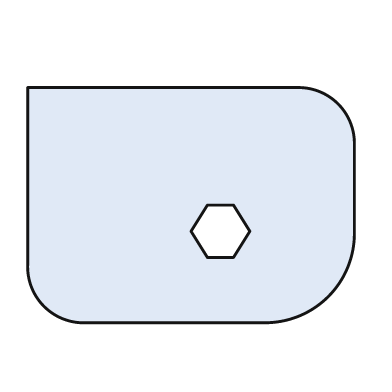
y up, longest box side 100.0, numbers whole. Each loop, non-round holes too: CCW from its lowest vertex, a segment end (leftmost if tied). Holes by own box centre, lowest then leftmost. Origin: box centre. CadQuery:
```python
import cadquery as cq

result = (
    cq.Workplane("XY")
    .moveTo(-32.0, -36.0)
    .lineTo(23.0, -36.0)
    .threePointArc((42.0, -28.0), (50.0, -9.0))
    .lineTo(50.0, 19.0)
    .threePointArc((45.0, 31.0), (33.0, 36.0))
    .lineTo(-50.0, 36.0)
    .lineTo(-50.0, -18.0)
    .threePointArc((-45.0, -31.0), (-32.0, -36.0))
    .close()
    .moveTo(5.0, -16.0)
    .lineTo(13.0, -16.0)
    .lineTo(18.0, -8.0)
    .lineTo(13.0, 0.0)
    .lineTo(5.0, 0.0)
    .lineTo(0.0, -8.0)
    .close()
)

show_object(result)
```